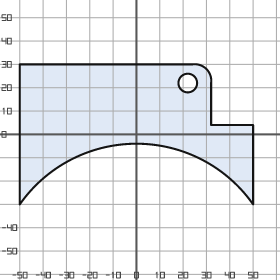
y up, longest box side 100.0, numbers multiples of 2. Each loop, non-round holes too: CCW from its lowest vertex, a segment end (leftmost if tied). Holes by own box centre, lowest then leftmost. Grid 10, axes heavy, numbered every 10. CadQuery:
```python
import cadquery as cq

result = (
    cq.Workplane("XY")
    .moveTo(-50.0, -30.0)
    .threePointArc((0.0, -4.0), (50.0, -30.0))
    .lineTo(50.0, 4.0)
    .lineTo(32.0, 4.0)
    .lineTo(32.0, 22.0)
    .threePointArc((30.0, 28.0), (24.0, 30.0))
    .lineTo(-50.0, 30.0)
    .close()
    .moveTo(22.0, 22.0)
    .circle(4.0)
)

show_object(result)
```